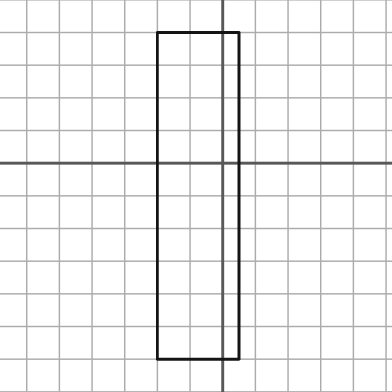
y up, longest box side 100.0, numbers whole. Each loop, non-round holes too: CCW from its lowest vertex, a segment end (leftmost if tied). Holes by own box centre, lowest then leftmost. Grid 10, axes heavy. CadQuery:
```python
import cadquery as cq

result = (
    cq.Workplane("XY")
    .moveTo(-20.0, -60.0)
    .lineTo(5.0, -60.0)
    .lineTo(5.0, 40.0)
    .lineTo(-20.0, 40.0)
    .close()
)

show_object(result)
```